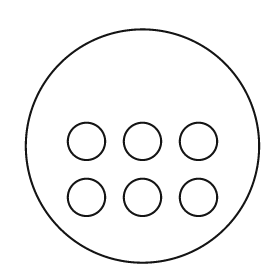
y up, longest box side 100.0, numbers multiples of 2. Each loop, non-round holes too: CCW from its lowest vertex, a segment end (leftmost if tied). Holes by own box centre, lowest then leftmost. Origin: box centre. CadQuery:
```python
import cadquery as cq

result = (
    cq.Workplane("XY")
    .moveTo(0.0, 0.0)
    .circle(50.0)
    .moveTo(-24.0, -22.0)
    .circle(8.0)
    .moveTo(0.0, -22.0)
    .circle(8.0)
    .moveTo(24.0, -22.0)
    .circle(8.0)
    .moveTo(-24.0, 2.0)
    .circle(8.0)
    .moveTo(0.0, 2.0)
    .circle(8.0)
    .moveTo(24.0, 2.0)
    .circle(8.0)
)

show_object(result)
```